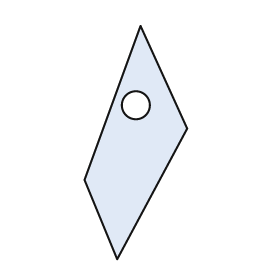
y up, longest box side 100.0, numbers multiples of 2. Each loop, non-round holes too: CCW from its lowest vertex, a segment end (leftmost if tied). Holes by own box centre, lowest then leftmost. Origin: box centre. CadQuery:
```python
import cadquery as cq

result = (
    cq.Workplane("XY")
    .moveTo(-8.0, -50.0)
    .lineTo(22.0, 6.0)
    .lineTo(2.0, 50.0)
    .lineTo(-22.0, -16.0)
    .close()
    .moveTo(0.0, 16.0)
    .circle(6.0)
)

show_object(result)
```